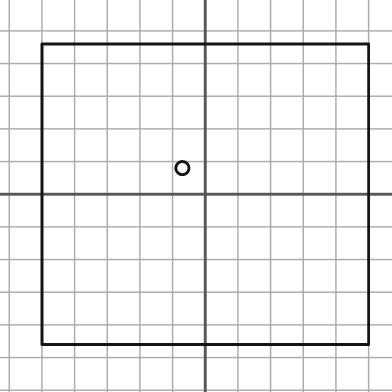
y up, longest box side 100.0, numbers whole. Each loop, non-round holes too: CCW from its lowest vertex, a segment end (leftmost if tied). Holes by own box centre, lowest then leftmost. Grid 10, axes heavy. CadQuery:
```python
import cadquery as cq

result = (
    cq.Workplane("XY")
    .moveTo(-50.0, -46.0)
    .lineTo(50.0, -46.0)
    .lineTo(50.0, 46.0)
    .lineTo(-50.0, 46.0)
    .close()
    .moveTo(-7.0, 8.0)
    .circle(2.0)
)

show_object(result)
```